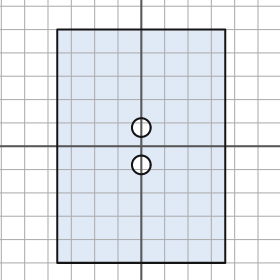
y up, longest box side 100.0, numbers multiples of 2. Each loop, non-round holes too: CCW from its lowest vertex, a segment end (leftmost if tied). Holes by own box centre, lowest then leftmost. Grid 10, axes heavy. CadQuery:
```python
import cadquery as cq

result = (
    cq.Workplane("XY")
    .moveTo(-36.0, -50.0)
    .lineTo(36.0, -50.0)
    .lineTo(36.0, 50.0)
    .lineTo(-36.0, 50.0)
    .close()
    .moveTo(0.0, -8.0)
    .circle(4.0)
    .moveTo(0.0, 8.0)
    .circle(4.0)
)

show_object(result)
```